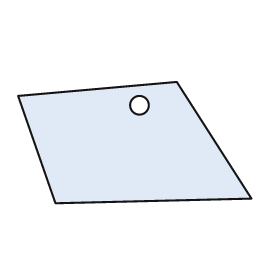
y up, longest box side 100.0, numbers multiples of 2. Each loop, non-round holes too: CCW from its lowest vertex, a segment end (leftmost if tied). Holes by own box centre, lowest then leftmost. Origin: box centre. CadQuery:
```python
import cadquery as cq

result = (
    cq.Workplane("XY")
    .moveTo(-34.0, -26.0)
    .lineTo(50.0, -24.0)
    .lineTo(18.0, 26.0)
    .lineTo(-50.0, 20.0)
    .close()
    .moveTo(2.0, 16.0)
    .circle(4.0)
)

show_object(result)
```